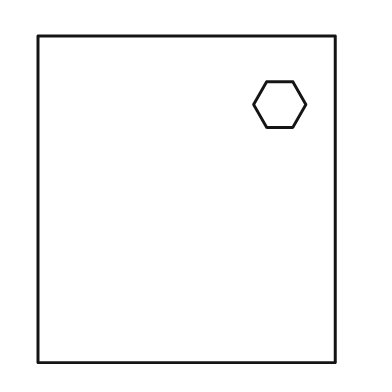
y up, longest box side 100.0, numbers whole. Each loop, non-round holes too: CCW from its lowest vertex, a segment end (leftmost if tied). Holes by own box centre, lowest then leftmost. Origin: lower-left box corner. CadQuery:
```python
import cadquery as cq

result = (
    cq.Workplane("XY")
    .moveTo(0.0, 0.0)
    .lineTo(91.0, 0.0)
    .lineTo(91.0, 100.0)
    .lineTo(0.0, 100.0)
    .close()
    .moveTo(70.0, 72.0)
    .lineTo(78.0, 72.0)
    .lineTo(82.0, 79.0)
    .lineTo(78.0, 86.0)
    .lineTo(70.0, 86.0)
    .lineTo(66.0, 79.0)
    .close()
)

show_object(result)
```